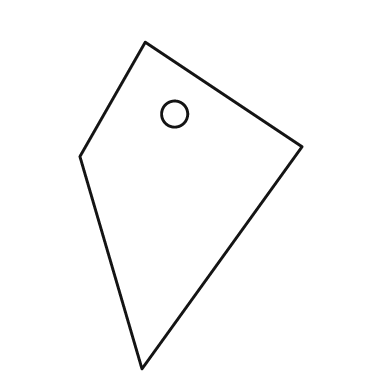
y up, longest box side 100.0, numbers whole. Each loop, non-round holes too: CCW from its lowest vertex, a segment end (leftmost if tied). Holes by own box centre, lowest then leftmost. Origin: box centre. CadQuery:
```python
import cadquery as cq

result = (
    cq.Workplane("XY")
    .moveTo(-15.0, -50.0)
    .lineTo(34.0, 18.0)
    .lineTo(-14.0, 50.0)
    .lineTo(-34.0, 15.0)
    .close()
    .moveTo(-5.0, 28.0)
    .circle(4.0)
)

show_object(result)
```